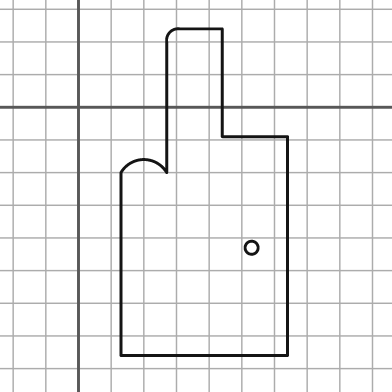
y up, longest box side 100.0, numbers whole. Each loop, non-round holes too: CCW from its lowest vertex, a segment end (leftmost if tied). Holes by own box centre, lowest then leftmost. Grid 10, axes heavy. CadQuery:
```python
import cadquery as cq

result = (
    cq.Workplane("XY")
    .moveTo(13.0, -76.0)
    .lineTo(64.0, -76.0)
    .lineTo(64.0, -9.0)
    .lineTo(44.0, -9.0)
    .lineTo(44.0, 24.0)
    .lineTo(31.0, 24.0)
    .threePointArc((28.0, 23.0), (27.0, 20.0))
    .lineTo(27.0, -20.0)
    .threePointArc((20.0, -16.0), (13.0, -20.0))
    .close()
    .moveTo(53.0, -43.0)
    .circle(2.0)
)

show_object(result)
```